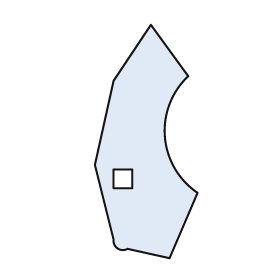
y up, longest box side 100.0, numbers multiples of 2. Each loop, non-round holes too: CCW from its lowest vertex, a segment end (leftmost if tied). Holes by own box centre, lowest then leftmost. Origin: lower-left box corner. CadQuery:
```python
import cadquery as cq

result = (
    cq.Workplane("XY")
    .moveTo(32.0, 0.0)
    .lineTo(44.0, 28.0)
    .threePointArc((30.0, 52.0), (40.0, 78.0))
    .lineTo(24.0, 100.0)
    .lineTo(8.0, 76.0)
    .lineTo(0.0, 40.0)
    .lineTo(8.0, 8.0)
    .threePointArc((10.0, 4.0), (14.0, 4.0))
    .close()
    .moveTo(8.0, 30.0)
    .lineTo(16.0, 30.0)
    .lineTo(16.0, 38.0)
    .lineTo(8.0, 38.0)
    .close()
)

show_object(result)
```